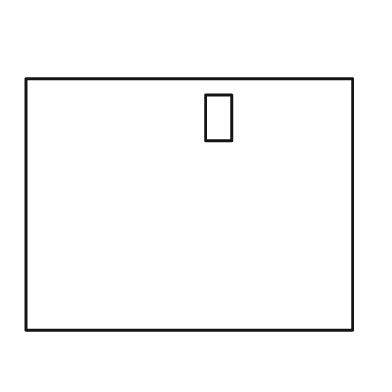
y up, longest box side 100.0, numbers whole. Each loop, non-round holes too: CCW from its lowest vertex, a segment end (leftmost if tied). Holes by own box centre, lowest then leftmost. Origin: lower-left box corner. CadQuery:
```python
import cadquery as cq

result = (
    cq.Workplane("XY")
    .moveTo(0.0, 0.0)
    .lineTo(100.0, 0.0)
    .lineTo(100.0, 77.0)
    .lineTo(0.0, 77.0)
    .close()
    .moveTo(55.0, 58.0)
    .lineTo(63.0, 58.0)
    .lineTo(63.0, 72.0)
    .lineTo(55.0, 72.0)
    .close()
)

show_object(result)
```